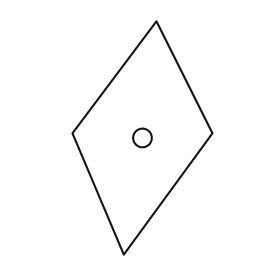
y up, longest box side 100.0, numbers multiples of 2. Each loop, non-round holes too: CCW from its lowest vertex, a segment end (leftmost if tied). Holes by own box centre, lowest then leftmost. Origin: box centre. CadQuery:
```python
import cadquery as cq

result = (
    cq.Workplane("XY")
    .moveTo(-8.0, -50.0)
    .lineTo(30.0, 2.0)
    .lineTo(6.0, 50.0)
    .lineTo(-30.0, 2.0)
    .close()
    .moveTo(0.0, 0.0)
    .circle(4.0)
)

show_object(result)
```